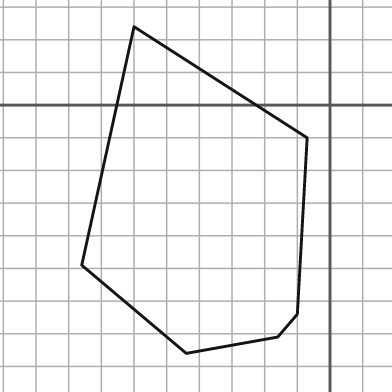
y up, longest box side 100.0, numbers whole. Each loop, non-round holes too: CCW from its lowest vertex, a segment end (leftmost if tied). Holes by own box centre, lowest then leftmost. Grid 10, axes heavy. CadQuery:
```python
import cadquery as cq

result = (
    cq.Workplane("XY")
    .moveTo(-44.0, -76.0)
    .lineTo(-16.0, -71.0)
    .lineTo(-10.0, -64.0)
    .lineTo(-7.0, -10.0)
    .lineTo(-60.0, 24.0)
    .lineTo(-76.0, -49.0)
    .close()
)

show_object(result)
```